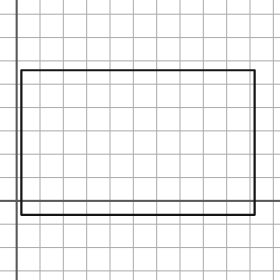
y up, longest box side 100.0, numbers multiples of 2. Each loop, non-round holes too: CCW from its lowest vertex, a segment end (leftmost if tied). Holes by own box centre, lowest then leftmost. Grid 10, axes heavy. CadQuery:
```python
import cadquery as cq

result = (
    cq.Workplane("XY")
    .moveTo(2.0, -6.0)
    .lineTo(102.0, -6.0)
    .lineTo(102.0, 56.0)
    .lineTo(2.0, 56.0)
    .close()
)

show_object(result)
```